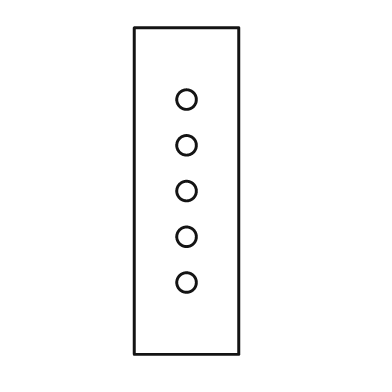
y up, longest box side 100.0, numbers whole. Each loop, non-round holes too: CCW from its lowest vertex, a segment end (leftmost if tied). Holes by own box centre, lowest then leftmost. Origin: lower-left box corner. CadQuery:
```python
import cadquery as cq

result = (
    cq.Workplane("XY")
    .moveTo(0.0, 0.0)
    .lineTo(32.0, 0.0)
    .lineTo(32.0, 100.0)
    .lineTo(0.0, 100.0)
    .close()
    .moveTo(16.0, 22.0)
    .circle(3.0)
    .moveTo(16.0, 36.0)
    .circle(3.0)
    .moveTo(16.0, 50.0)
    .circle(3.0)
    .moveTo(16.0, 64.0)
    .circle(3.0)
    .moveTo(16.0, 78.0)
    .circle(3.0)
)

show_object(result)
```